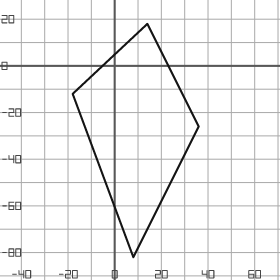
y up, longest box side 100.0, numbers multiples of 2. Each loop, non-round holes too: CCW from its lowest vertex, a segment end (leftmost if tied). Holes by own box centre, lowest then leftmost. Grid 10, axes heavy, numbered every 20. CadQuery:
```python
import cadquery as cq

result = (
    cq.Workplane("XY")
    .moveTo(8.0, -82.0)
    .lineTo(36.0, -26.0)
    .lineTo(14.0, 18.0)
    .lineTo(-18.0, -12.0)
    .close()
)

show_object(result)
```